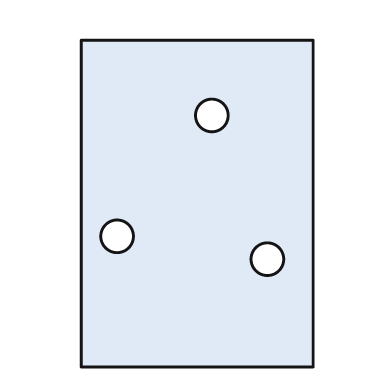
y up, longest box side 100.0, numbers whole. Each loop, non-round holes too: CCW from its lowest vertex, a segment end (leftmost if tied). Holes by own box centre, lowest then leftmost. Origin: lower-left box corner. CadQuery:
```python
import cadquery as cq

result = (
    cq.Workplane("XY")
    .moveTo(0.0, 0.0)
    .lineTo(71.0, 0.0)
    .lineTo(71.0, 100.0)
    .lineTo(0.0, 100.0)
    .close()
    .moveTo(57.0, 33.0)
    .circle(5.0)
    .moveTo(11.0, 40.0)
    .circle(5.0)
    .moveTo(40.0, 77.0)
    .circle(5.0)
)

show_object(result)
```